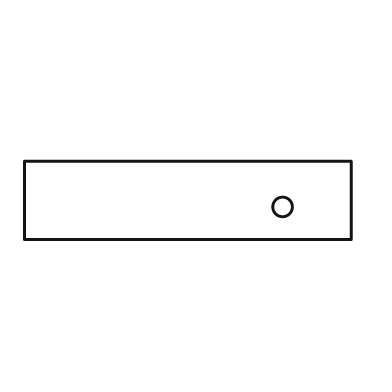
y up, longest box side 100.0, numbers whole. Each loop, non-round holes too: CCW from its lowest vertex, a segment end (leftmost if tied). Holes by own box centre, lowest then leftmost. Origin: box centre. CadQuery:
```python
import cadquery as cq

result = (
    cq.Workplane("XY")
    .moveTo(-50.0, -12.0)
    .lineTo(50.0, -12.0)
    .lineTo(50.0, 12.0)
    .lineTo(-50.0, 12.0)
    .close()
    .moveTo(29.0, -2.0)
    .circle(3.0)
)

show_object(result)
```